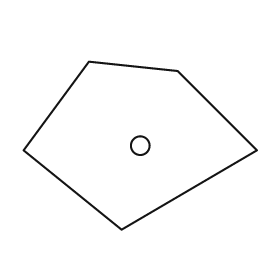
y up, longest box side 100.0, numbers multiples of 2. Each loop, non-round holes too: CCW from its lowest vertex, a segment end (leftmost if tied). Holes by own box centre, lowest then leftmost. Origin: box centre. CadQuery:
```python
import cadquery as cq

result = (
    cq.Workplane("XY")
    .moveTo(-8.0, -36.0)
    .lineTo(50.0, -2.0)
    .lineTo(16.0, 32.0)
    .lineTo(-22.0, 36.0)
    .lineTo(-50.0, -2.0)
    .close()
    .moveTo(0.0, 0.0)
    .circle(4.0)
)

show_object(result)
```